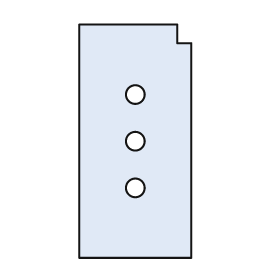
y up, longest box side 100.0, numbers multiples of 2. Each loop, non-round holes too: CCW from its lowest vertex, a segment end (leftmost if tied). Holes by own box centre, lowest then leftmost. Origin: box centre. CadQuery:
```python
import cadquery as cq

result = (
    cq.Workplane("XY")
    .moveTo(-24.0, -50.0)
    .lineTo(24.0, -50.0)
    .lineTo(24.0, 42.0)
    .lineTo(18.0, 42.0)
    .lineTo(18.0, 50.0)
    .lineTo(-24.0, 50.0)
    .close()
    .moveTo(0.0, -20.0)
    .circle(4.0)
    .moveTo(0.0, 0.0)
    .circle(4.0)
    .moveTo(0.0, 20.0)
    .circle(4.0)
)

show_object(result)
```